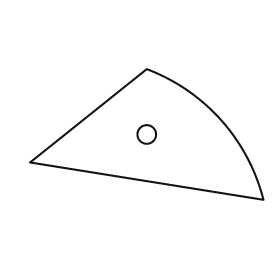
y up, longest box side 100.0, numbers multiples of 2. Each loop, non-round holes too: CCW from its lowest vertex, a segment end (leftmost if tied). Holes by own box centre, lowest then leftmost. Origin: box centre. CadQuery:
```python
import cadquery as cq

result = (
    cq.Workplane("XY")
    .moveTo(50.0, -28.0)
    .threePointArc((32.0, 6.0), (0.0, 28.0))
    .lineTo(-50.0, -12.0)
    .close()
    .moveTo(0.0, 0.0)
    .circle(4.0)
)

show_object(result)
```